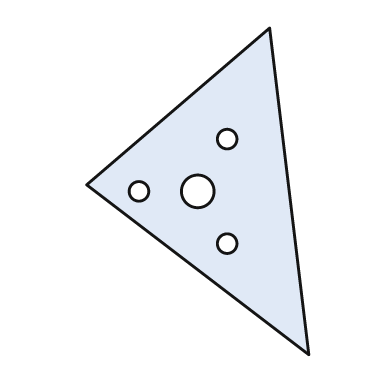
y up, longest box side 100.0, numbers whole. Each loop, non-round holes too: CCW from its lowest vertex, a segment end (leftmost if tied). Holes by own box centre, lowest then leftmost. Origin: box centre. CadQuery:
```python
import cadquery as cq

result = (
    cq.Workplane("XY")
    .moveTo(34.0, -50.0)
    .lineTo(22.0, 50.0)
    .lineTo(-34.0, 2.0)
    .close()
    .moveTo(9.0, -16.0)
    .circle(3.0)
    .moveTo(-18.0, 0.0)
    .circle(3.0)
    .moveTo(0.0, 0.0)
    .circle(5.0)
    .moveTo(9.0, 16.0)
    .circle(3.0)
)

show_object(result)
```